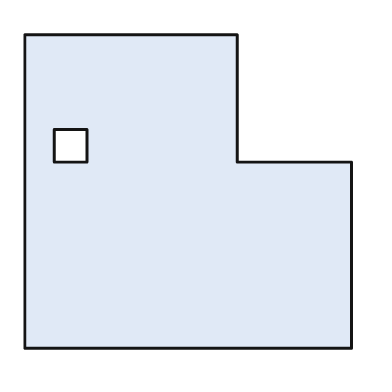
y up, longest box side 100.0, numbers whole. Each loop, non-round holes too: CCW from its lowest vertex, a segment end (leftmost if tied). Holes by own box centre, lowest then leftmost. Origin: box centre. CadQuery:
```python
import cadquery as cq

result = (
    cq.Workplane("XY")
    .moveTo(-50.0, -48.0)
    .lineTo(50.0, -48.0)
    .lineTo(50.0, 9.0)
    .lineTo(15.0, 9.0)
    .lineTo(15.0, 48.0)
    .lineTo(-50.0, 48.0)
    .close()
    .moveTo(-41.0, 9.0)
    .lineTo(-31.0, 9.0)
    .lineTo(-31.0, 19.0)
    .lineTo(-41.0, 19.0)
    .close()
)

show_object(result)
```